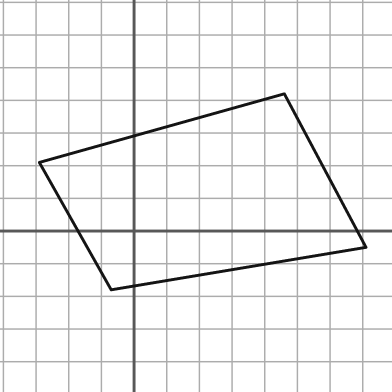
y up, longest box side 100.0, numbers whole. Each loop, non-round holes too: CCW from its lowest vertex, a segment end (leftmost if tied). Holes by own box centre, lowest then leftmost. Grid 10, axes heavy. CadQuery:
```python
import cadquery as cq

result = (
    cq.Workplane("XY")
    .moveTo(-7.0, -18.0)
    .lineTo(71.0, -5.0)
    .lineTo(46.0, 42.0)
    .lineTo(-29.0, 21.0)
    .close()
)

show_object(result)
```